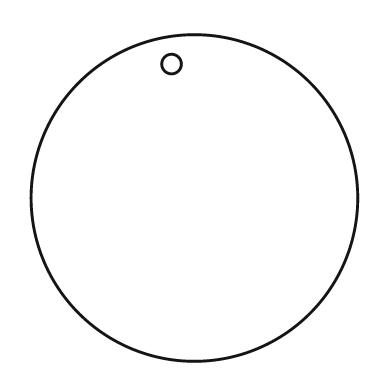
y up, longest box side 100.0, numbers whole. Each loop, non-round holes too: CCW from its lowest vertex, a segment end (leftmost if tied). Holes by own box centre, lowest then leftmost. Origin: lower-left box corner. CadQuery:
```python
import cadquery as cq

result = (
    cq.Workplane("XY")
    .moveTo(50.0, 50.0)
    .circle(50.0)
    .moveTo(43.0, 91.0)
    .circle(3.0)
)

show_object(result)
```